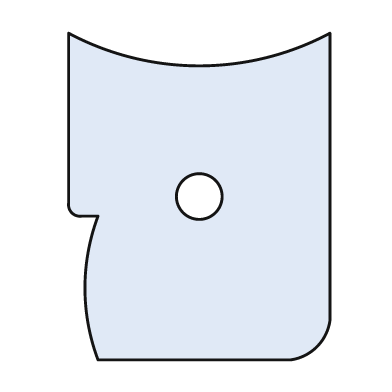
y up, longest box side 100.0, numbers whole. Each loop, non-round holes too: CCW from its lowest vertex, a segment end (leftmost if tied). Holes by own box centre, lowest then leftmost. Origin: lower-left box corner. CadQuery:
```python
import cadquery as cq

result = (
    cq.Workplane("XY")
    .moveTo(9.0, 0.0)
    .lineTo(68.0, 0.0)
    .threePointArc((76.0, 4.0), (80.0, 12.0))
    .lineTo(80.0, 100.0)
    .threePointArc((40.0, 90.0), (0.0, 100.0))
    .lineTo(0.0, 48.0)
    .threePointArc((1.0, 45.0), (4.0, 44.0))
    .lineTo(9.0, 44.0)
    .threePointArc((5.0, 22.0), (9.0, 0.0))
    .close()
    .moveTo(40.0, 50.0)
    .circle(7.0)
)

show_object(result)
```